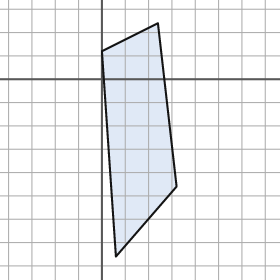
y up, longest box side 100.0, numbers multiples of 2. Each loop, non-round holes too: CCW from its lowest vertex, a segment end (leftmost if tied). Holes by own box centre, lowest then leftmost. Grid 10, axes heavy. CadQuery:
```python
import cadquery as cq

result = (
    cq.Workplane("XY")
    .moveTo(6.0, -76.0)
    .lineTo(32.0, -46.0)
    .lineTo(24.0, 24.0)
    .lineTo(0.0, 12.0)
    .close()
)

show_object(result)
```